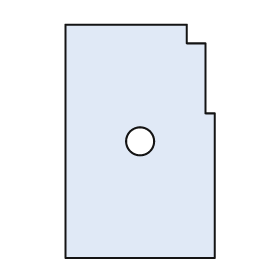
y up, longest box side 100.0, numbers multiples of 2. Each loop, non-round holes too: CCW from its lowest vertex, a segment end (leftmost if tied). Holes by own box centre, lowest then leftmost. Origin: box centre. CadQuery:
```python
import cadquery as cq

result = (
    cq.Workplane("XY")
    .moveTo(-32.0, -50.0)
    .lineTo(32.0, -50.0)
    .lineTo(32.0, 12.0)
    .lineTo(28.0, 12.0)
    .lineTo(28.0, 42.0)
    .lineTo(20.0, 42.0)
    .lineTo(20.0, 50.0)
    .lineTo(-32.0, 50.0)
    .close()
    .moveTo(0.0, 0.0)
    .circle(6.0)
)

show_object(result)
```